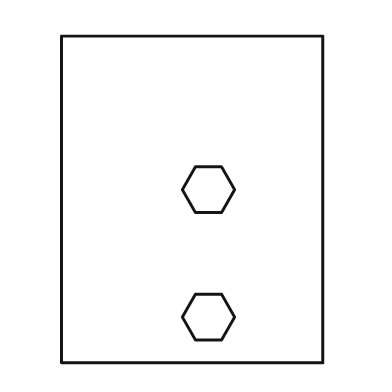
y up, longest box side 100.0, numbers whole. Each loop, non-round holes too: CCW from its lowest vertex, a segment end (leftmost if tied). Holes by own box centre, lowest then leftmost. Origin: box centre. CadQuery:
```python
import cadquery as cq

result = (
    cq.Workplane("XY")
    .moveTo(-40.0, -50.0)
    .lineTo(40.0, -50.0)
    .lineTo(40.0, 50.0)
    .lineTo(-40.0, 50.0)
    .close()
    .moveTo(1.0, -43.0)
    .lineTo(9.0, -43.0)
    .lineTo(13.0, -36.0)
    .lineTo(9.0, -29.0)
    .lineTo(1.0, -29.0)
    .lineTo(-3.0, -36.0)
    .close()
    .moveTo(1.0, -4.0)
    .lineTo(9.0, -4.0)
    .lineTo(13.0, 3.0)
    .lineTo(9.0, 10.0)
    .lineTo(1.0, 10.0)
    .lineTo(-3.0, 3.0)
    .close()
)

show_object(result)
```